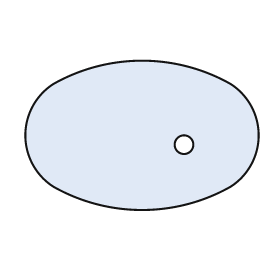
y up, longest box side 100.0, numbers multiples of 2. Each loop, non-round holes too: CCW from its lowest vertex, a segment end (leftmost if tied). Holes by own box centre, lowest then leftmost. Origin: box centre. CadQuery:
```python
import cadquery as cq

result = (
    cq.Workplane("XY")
    .moveTo(-38.0, -22.0)
    .threePointArc((0.0, -32.0), (38.0, -22.0))
    .threePointArc((50.0, 0.0), (38.0, 22.0))
    .threePointArc((0.0, 32.0), (-38.0, 22.0))
    .threePointArc((-50.0, 0.0), (-38.0, -22.0))
    .close()
    .moveTo(18.0, -4.0)
    .circle(4.0)
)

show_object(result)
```